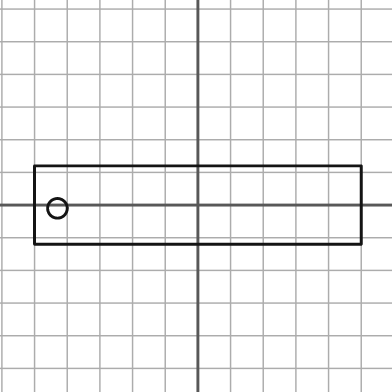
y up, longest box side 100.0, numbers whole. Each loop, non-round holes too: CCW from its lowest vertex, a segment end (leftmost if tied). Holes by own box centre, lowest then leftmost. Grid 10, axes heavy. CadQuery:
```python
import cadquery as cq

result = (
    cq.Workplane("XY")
    .moveTo(-50.0, -12.0)
    .lineTo(50.0, -12.0)
    .lineTo(50.0, 12.0)
    .lineTo(-50.0, 12.0)
    .close()
    .moveTo(-43.0, -1.0)
    .circle(3.0)
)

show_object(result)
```